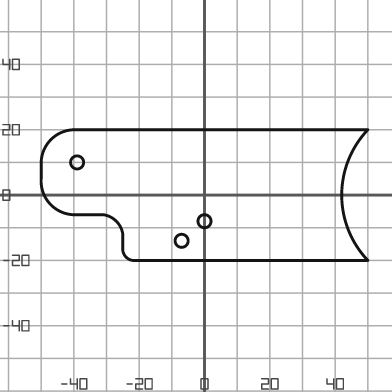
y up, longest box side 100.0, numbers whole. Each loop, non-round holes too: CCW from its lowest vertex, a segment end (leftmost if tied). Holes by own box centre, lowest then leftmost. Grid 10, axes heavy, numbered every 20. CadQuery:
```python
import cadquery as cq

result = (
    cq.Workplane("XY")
    .moveTo(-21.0, -20.0)
    .lineTo(50.0, -20.0)
    .threePointArc((42.0, 0.0), (50.0, 20.0))
    .lineTo(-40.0, 20.0)
    .threePointArc((-47.0, 17.0), (-50.0, 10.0))
    .lineTo(-50.0, 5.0)
    .threePointArc((-47.0, -3.0), (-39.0, -6.0))
    .lineTo(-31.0, -6.0)
    .threePointArc((-27.0, -8.0), (-25.0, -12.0))
    .lineTo(-25.0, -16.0)
    .threePointArc((-24.0, -19.0), (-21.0, -20.0))
    .close()
    .moveTo(-7.0, -14.0)
    .circle(2.0)
    .moveTo(0.0, -8.0)
    .circle(2.0)
    .moveTo(-39.0, 10.0)
    .circle(2.0)
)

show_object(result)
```